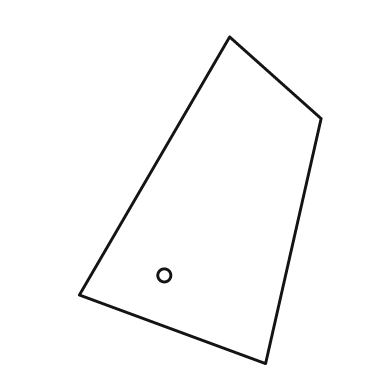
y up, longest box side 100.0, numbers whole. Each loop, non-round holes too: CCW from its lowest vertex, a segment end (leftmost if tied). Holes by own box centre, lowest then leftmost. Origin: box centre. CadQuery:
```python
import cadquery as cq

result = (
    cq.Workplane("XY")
    .moveTo(20.0, -50.0)
    .lineTo(37.0, 25.0)
    .lineTo(9.0, 50.0)
    .lineTo(-37.0, -29.0)
    .close()
    .moveTo(-11.0, -23.0)
    .circle(2.0)
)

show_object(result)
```